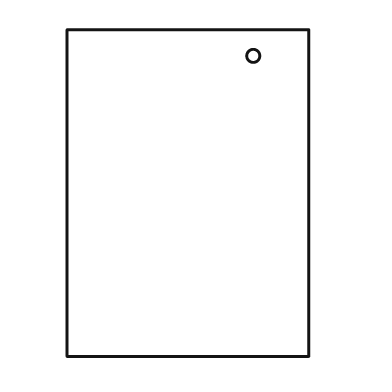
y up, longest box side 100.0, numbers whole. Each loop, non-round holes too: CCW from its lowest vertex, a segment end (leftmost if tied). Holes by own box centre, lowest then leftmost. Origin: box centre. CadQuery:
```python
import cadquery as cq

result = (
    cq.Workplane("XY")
    .moveTo(-37.0, -50.0)
    .lineTo(37.0, -50.0)
    .lineTo(37.0, 50.0)
    .lineTo(-37.0, 50.0)
    .close()
    .moveTo(20.0, 42.0)
    .circle(2.0)
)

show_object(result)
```